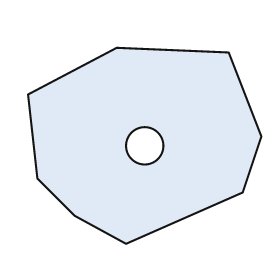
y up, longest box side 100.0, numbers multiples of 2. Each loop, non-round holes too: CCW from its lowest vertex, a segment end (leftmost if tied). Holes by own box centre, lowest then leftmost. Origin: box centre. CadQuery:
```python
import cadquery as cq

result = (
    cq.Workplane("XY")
    .moveTo(-8.0, -42.0)
    .lineTo(42.0, -20.0)
    .lineTo(50.0, 4.0)
    .lineTo(36.0, 40.0)
    .lineTo(-12.0, 42.0)
    .lineTo(-50.0, 22.0)
    .lineTo(-46.0, -14.0)
    .lineTo(-30.0, -30.0)
    .close()
    .moveTo(0.0, 0.0)
    .circle(8.0)
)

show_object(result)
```